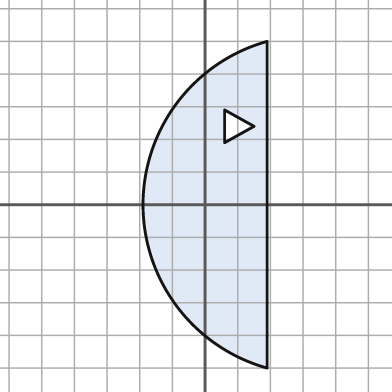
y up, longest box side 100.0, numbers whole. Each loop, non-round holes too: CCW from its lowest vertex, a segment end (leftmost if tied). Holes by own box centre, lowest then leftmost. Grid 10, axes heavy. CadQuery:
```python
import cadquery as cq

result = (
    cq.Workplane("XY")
    .moveTo(19.0, -50.0)
    .lineTo(19.0, 50.0)
    .threePointArc((-19.0, 0.0), (19.0, -50.0))
    .close()
    .moveTo(6.0, 19.0)
    .lineTo(15.0, 24.0)
    .lineTo(6.0, 29.0)
    .close()
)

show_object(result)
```